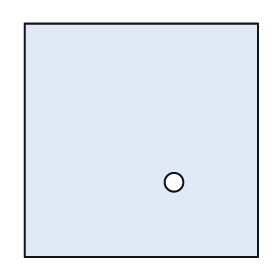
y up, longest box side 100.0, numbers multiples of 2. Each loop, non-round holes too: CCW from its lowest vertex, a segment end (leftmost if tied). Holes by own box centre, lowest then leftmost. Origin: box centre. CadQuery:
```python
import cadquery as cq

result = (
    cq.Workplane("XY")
    .moveTo(-50.0, -50.0)
    .lineTo(50.0, -50.0)
    .lineTo(50.0, 50.0)
    .lineTo(-50.0, 50.0)
    .close()
    .moveTo(14.0, -18.0)
    .circle(4.0)
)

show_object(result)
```